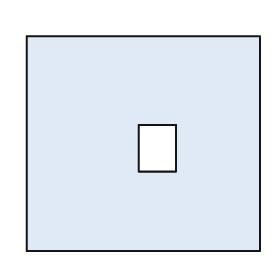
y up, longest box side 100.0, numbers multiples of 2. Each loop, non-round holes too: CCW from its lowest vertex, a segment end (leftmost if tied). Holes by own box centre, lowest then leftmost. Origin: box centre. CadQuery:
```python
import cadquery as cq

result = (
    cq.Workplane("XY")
    .moveTo(-50.0, -46.0)
    .lineTo(50.0, -46.0)
    .lineTo(50.0, 46.0)
    .lineTo(-50.0, 46.0)
    .close()
    .moveTo(-2.0, -12.0)
    .lineTo(14.0, -12.0)
    .lineTo(14.0, 8.0)
    .lineTo(-2.0, 8.0)
    .close()
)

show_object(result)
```